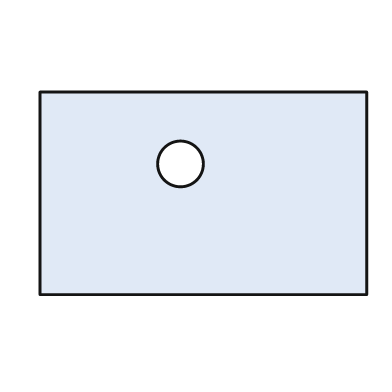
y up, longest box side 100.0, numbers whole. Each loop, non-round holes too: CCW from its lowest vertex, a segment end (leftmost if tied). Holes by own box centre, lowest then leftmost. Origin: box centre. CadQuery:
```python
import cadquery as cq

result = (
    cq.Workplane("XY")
    .moveTo(-50.0, -31.0)
    .lineTo(50.0, -31.0)
    .lineTo(50.0, 31.0)
    .lineTo(-50.0, 31.0)
    .close()
    .moveTo(-7.0, 9.0)
    .circle(7.0)
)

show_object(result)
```